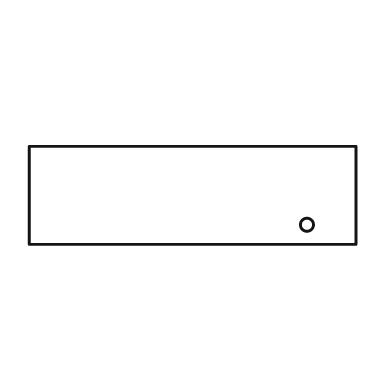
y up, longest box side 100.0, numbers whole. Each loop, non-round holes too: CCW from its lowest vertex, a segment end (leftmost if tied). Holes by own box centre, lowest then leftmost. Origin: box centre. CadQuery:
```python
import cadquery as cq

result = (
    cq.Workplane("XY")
    .moveTo(-50.0, -15.0)
    .lineTo(50.0, -15.0)
    .lineTo(50.0, 15.0)
    .lineTo(-50.0, 15.0)
    .close()
    .moveTo(35.0, -9.0)
    .circle(2.0)
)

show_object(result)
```